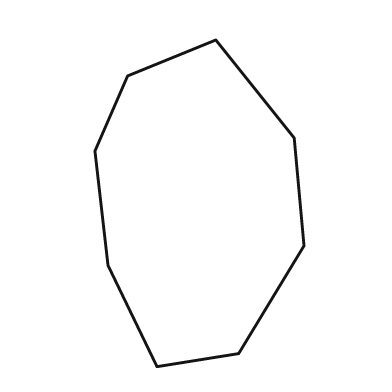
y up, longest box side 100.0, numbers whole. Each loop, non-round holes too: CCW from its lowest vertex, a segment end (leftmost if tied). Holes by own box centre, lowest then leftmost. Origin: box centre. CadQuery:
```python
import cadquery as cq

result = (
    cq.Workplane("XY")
    .moveTo(-13.0, -50.0)
    .lineTo(12.0, -46.0)
    .lineTo(32.0, -13.0)
    .lineTo(29.0, 20.0)
    .lineTo(5.0, 50.0)
    .lineTo(-22.0, 39.0)
    .lineTo(-32.0, 16.0)
    .lineTo(-28.0, -19.0)
    .close()
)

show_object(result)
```